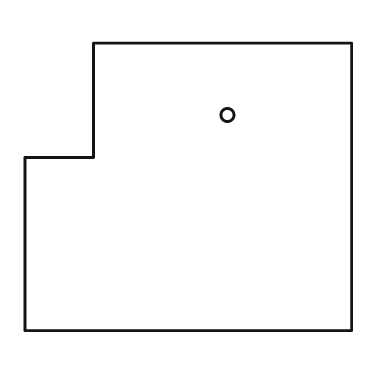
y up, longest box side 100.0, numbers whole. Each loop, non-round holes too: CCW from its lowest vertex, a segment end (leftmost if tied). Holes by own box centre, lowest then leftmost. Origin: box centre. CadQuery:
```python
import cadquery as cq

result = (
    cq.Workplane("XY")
    .moveTo(-50.0, -44.0)
    .lineTo(50.0, -44.0)
    .lineTo(50.0, 44.0)
    .lineTo(-29.0, 44.0)
    .lineTo(-29.0, 9.0)
    .lineTo(-50.0, 9.0)
    .close()
    .moveTo(12.0, 22.0)
    .circle(2.0)
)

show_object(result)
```